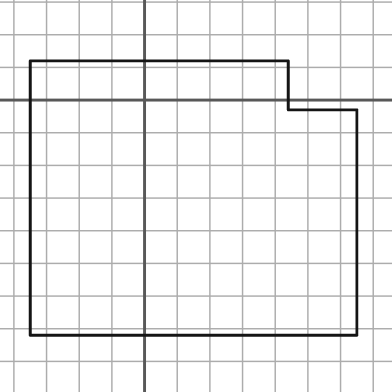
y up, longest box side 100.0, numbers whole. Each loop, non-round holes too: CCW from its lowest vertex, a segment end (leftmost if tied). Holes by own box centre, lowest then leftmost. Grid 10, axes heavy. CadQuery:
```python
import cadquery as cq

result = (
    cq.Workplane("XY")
    .moveTo(-35.0, -72.0)
    .lineTo(65.0, -72.0)
    .lineTo(65.0, -3.0)
    .lineTo(44.0, -3.0)
    .lineTo(44.0, 12.0)
    .lineTo(-35.0, 12.0)
    .close()
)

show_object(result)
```